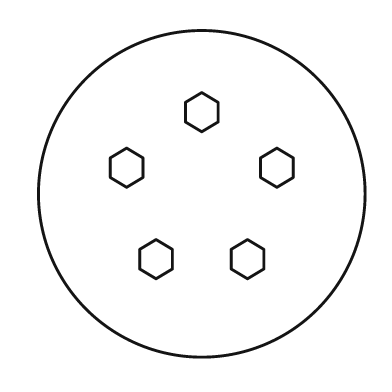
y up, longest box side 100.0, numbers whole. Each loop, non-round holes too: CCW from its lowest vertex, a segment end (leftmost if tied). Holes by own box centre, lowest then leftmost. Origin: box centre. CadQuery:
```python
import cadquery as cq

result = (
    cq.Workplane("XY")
    .moveTo(0.0, 0.0)
    .circle(50.0)
    .moveTo(-14.0, -26.0)
    .lineTo(-9.0, -23.0)
    .lineTo(-9.0, -17.0)
    .lineTo(-14.0, -14.0)
    .lineTo(-19.0, -17.0)
    .lineTo(-19.0, -23.0)
    .close()
    .moveTo(14.0, -26.0)
    .lineTo(19.0, -23.0)
    .lineTo(19.0, -17.0)
    .lineTo(14.0, -14.0)
    .lineTo(9.0, -17.0)
    .lineTo(9.0, -23.0)
    .close()
    .moveTo(-23.0, 2.0)
    .lineTo(-18.0, 5.0)
    .lineTo(-18.0, 11.0)
    .lineTo(-23.0, 14.0)
    .lineTo(-28.0, 11.0)
    .lineTo(-28.0, 5.0)
    .close()
    .moveTo(23.0, 2.0)
    .lineTo(28.0, 5.0)
    .lineTo(28.0, 11.0)
    .lineTo(23.0, 14.0)
    .lineTo(18.0, 11.0)
    .lineTo(18.0, 5.0)
    .close()
    .moveTo(0.0, 19.0)
    .lineTo(5.0, 22.0)
    .lineTo(5.0, 28.0)
    .lineTo(0.0, 31.0)
    .lineTo(-5.0, 28.0)
    .lineTo(-5.0, 22.0)
    .close()
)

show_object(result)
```